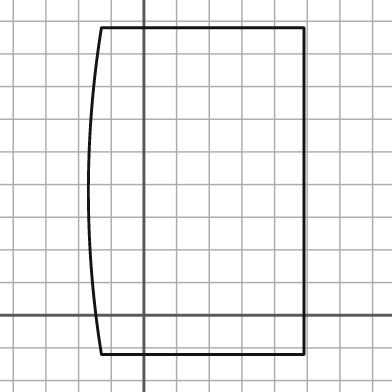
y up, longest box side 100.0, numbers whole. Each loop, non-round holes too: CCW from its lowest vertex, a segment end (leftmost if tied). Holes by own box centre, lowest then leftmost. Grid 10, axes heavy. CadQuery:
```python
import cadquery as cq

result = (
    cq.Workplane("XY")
    .moveTo(-13.0, -12.0)
    .lineTo(49.0, -12.0)
    .lineTo(49.0, 88.0)
    .lineTo(-13.0, 88.0)
    .threePointArc((-17.0, 38.0), (-13.0, -12.0))
    .close()
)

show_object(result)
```